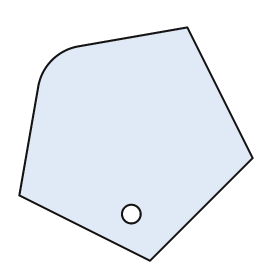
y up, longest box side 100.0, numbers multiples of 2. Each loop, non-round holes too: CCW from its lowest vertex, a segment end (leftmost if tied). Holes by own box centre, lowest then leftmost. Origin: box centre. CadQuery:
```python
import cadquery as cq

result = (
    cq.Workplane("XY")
    .moveTo(6.0, -50.0)
    .lineTo(50.0, -6.0)
    .lineTo(22.0, 50.0)
    .lineTo(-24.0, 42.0)
    .threePointArc((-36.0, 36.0), (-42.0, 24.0))
    .lineTo(-50.0, -22.0)
    .close()
    .moveTo(-2.0, -30.0)
    .circle(4.0)
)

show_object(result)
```